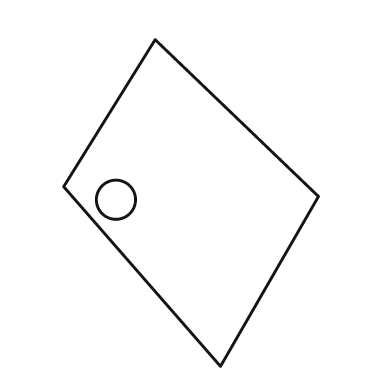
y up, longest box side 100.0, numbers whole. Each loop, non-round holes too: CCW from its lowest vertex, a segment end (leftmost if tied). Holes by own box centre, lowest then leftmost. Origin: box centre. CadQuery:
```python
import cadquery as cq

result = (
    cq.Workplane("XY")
    .moveTo(9.0, -50.0)
    .lineTo(39.0, 2.0)
    .lineTo(-11.0, 50.0)
    .lineTo(-39.0, 5.0)
    .close()
    .moveTo(-23.0, 1.0)
    .circle(6.0)
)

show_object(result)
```